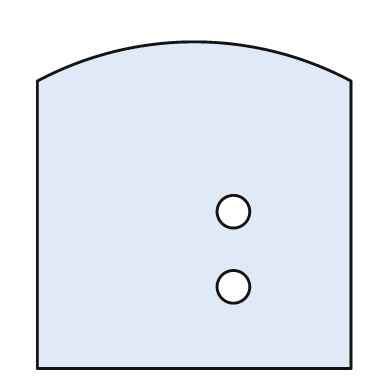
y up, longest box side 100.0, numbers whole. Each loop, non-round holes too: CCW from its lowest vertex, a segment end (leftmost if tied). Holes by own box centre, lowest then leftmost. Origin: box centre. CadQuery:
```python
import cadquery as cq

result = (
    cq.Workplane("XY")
    .moveTo(-48.0, -50.0)
    .lineTo(48.0, -50.0)
    .lineTo(48.0, 38.0)
    .threePointArc((0.0, 50.0), (-48.0, 38.0))
    .close()
    .moveTo(12.0, -25.0)
    .circle(5.0)
    .moveTo(12.0, -2.0)
    .circle(5.0)
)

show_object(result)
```